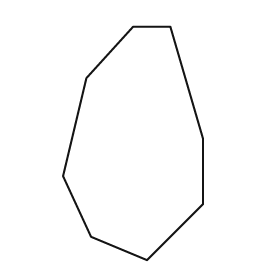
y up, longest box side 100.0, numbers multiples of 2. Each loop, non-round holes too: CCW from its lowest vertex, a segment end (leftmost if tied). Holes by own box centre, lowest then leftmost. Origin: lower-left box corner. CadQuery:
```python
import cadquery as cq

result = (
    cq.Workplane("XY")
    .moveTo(36.0, 0.0)
    .lineTo(60.0, 24.0)
    .lineTo(60.0, 52.0)
    .lineTo(46.0, 100.0)
    .lineTo(30.0, 100.0)
    .lineTo(10.0, 78.0)
    .lineTo(0.0, 36.0)
    .lineTo(12.0, 10.0)
    .close()
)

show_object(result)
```